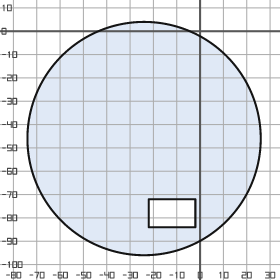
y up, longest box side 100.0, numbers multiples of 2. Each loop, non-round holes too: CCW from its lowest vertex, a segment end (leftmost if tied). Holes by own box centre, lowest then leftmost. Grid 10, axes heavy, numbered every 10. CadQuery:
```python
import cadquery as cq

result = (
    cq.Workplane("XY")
    .moveTo(-24.0, -46.0)
    .circle(50.0)
    .moveTo(-22.0, -84.0)
    .lineTo(-2.0, -84.0)
    .lineTo(-2.0, -72.0)
    .lineTo(-22.0, -72.0)
    .close()
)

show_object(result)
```